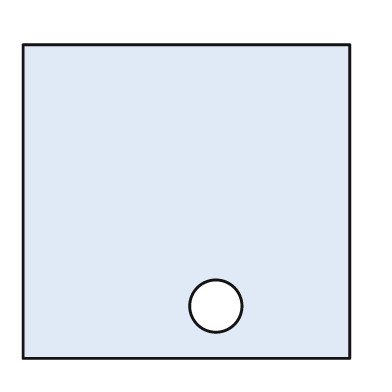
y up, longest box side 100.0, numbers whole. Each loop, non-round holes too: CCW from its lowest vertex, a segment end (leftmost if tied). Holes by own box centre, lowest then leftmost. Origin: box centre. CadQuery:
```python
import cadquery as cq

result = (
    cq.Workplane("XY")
    .moveTo(-50.0, -48.0)
    .lineTo(50.0, -48.0)
    .lineTo(50.0, 48.0)
    .lineTo(-50.0, 48.0)
    .close()
    .moveTo(9.0, -32.0)
    .circle(8.0)
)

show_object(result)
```